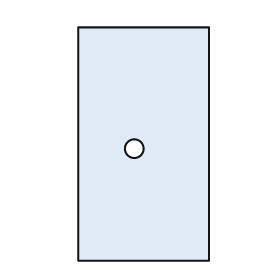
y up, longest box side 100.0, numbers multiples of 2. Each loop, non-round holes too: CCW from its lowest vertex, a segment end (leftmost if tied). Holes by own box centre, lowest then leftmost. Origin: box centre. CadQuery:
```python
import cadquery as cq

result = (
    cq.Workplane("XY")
    .moveTo(-28.0, -50.0)
    .lineTo(28.0, -50.0)
    .lineTo(28.0, 50.0)
    .lineTo(-28.0, 50.0)
    .close()
    .moveTo(-4.0, -2.0)
    .circle(4.0)
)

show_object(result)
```